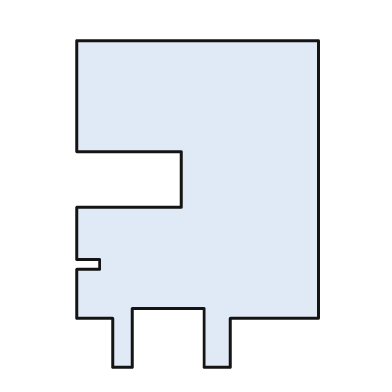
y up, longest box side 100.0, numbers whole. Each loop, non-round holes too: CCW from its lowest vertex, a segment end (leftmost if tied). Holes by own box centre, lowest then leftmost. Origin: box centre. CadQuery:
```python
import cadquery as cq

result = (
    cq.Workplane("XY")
    .moveTo(-26.0, -50.0)
    .lineTo(-20.0, -50.0)
    .lineTo(-20.0, -32.0)
    .lineTo(2.0, -32.0)
    .lineTo(2.0, -50.0)
    .lineTo(10.0, -50.0)
    .lineTo(10.0, -35.0)
    .lineTo(37.0, -35.0)
    .lineTo(37.0, 50.0)
    .lineTo(-37.0, 50.0)
    .lineTo(-37.0, 16.0)
    .lineTo(-5.0, 16.0)
    .lineTo(-5.0, -1.0)
    .lineTo(-37.0, -1.0)
    .lineTo(-37.0, -17.0)
    .lineTo(-30.0, -17.0)
    .lineTo(-30.0, -20.0)
    .lineTo(-37.0, -20.0)
    .lineTo(-37.0, -35.0)
    .lineTo(-26.0, -35.0)
    .close()
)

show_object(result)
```